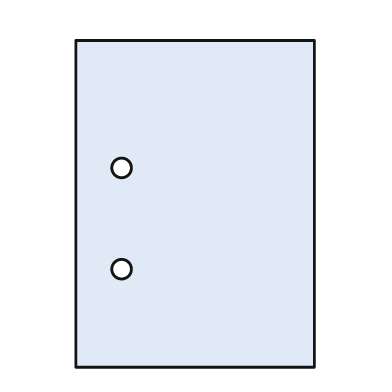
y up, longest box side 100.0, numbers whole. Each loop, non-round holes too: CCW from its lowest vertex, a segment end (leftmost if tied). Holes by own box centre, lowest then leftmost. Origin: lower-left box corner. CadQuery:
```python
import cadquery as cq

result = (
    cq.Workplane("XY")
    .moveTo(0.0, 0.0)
    .lineTo(73.0, 0.0)
    .lineTo(73.0, 100.0)
    .lineTo(0.0, 100.0)
    .close()
    .moveTo(14.0, 30.0)
    .circle(3.0)
    .moveTo(14.0, 61.0)
    .circle(3.0)
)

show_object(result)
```